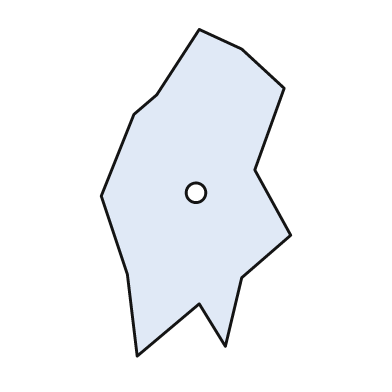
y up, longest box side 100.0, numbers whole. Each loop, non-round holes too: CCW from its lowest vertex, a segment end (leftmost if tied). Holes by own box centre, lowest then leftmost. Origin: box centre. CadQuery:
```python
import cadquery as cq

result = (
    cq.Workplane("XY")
    .moveTo(-18.0, -50.0)
    .lineTo(1.0, -34.0)
    .lineTo(9.0, -47.0)
    .lineTo(14.0, -26.0)
    .lineTo(29.0, -13.0)
    .lineTo(18.0, 7.0)
    .lineTo(27.0, 32.0)
    .lineTo(14.0, 44.0)
    .lineTo(1.0, 50.0)
    .lineTo(-12.0, 30.0)
    .lineTo(-19.0, 24.0)
    .lineTo(-29.0, -1.0)
    .lineTo(-21.0, -25.0)
    .close()
    .moveTo(0.0, 0.0)
    .circle(3.0)
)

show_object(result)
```